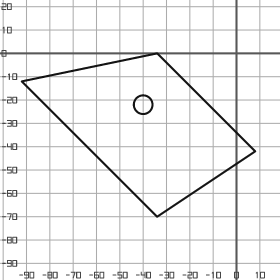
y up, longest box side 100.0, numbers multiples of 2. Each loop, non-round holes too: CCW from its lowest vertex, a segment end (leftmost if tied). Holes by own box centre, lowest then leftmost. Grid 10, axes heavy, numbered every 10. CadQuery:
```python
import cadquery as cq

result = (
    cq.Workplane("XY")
    .moveTo(-34.0, -70.0)
    .lineTo(8.0, -42.0)
    .lineTo(-34.0, 0.0)
    .lineTo(-92.0, -12.0)
    .close()
    .moveTo(-40.0, -22.0)
    .circle(4.0)
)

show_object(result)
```